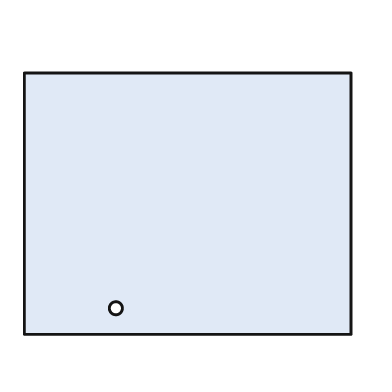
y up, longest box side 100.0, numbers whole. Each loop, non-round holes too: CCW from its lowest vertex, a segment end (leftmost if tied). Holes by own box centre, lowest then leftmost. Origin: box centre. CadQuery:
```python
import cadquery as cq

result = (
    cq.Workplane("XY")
    .moveTo(-50.0, -40.0)
    .lineTo(50.0, -40.0)
    .lineTo(50.0, 40.0)
    .lineTo(-50.0, 40.0)
    .close()
    .moveTo(-22.0, -32.0)
    .circle(2.0)
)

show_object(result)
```